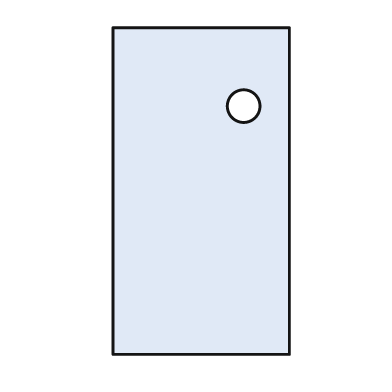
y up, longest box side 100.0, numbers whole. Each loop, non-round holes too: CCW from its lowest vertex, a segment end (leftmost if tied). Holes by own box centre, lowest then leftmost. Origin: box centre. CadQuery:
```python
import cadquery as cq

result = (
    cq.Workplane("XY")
    .moveTo(-27.0, -50.0)
    .lineTo(27.0, -50.0)
    .lineTo(27.0, 50.0)
    .lineTo(-27.0, 50.0)
    .close()
    .moveTo(13.0, 26.0)
    .circle(5.0)
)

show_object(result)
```